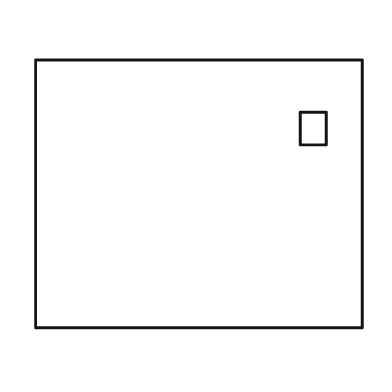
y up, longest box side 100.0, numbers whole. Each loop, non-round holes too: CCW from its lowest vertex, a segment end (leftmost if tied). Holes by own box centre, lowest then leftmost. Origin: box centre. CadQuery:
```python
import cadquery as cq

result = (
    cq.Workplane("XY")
    .moveTo(-50.0, -41.0)
    .lineTo(50.0, -41.0)
    .lineTo(50.0, 41.0)
    .lineTo(-50.0, 41.0)
    .close()
    .moveTo(31.0, 15.0)
    .lineTo(39.0, 15.0)
    .lineTo(39.0, 25.0)
    .lineTo(31.0, 25.0)
    .close()
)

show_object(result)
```